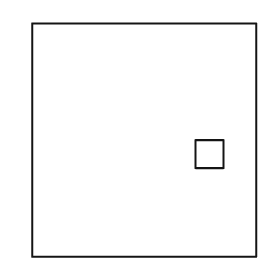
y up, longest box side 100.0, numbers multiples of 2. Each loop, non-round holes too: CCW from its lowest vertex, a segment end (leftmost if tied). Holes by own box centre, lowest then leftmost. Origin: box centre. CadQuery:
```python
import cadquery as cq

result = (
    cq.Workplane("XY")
    .moveTo(-48.0, -50.0)
    .lineTo(48.0, -50.0)
    .lineTo(48.0, 50.0)
    .lineTo(-48.0, 50.0)
    .close()
    .moveTo(22.0, -12.0)
    .lineTo(34.0, -12.0)
    .lineTo(34.0, 0.0)
    .lineTo(22.0, 0.0)
    .close()
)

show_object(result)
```